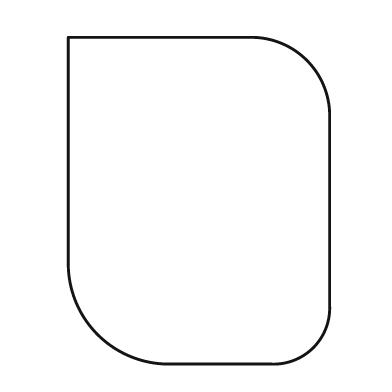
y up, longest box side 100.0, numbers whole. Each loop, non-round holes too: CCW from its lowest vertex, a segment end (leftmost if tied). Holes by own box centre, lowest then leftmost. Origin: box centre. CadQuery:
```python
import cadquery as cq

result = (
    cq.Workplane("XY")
    .moveTo(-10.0, -50.0)
    .lineTo(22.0, -50.0)
    .threePointArc((35.0, -45.0), (40.0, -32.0))
    .lineTo(40.0, 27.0)
    .threePointArc((33.0, 43.0), (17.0, 50.0))
    .lineTo(-40.0, 50.0)
    .lineTo(-40.0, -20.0)
    .threePointArc((-31.0, -41.0), (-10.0, -50.0))
    .close()
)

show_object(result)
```